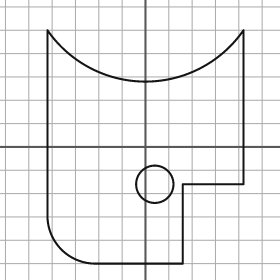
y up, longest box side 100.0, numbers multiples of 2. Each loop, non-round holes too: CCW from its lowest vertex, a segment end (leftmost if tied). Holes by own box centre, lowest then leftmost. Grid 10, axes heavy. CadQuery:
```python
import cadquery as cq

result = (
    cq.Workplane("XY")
    .moveTo(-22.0, -50.0)
    .lineTo(16.0, -50.0)
    .lineTo(16.0, -16.0)
    .lineTo(42.0, -16.0)
    .lineTo(42.0, 50.0)
    .threePointArc((0.0, 28.0), (-42.0, 50.0))
    .lineTo(-42.0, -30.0)
    .threePointArc((-36.0, -44.0), (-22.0, -50.0))
    .close()
    .moveTo(4.0, -16.0)
    .circle(8.0)
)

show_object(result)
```